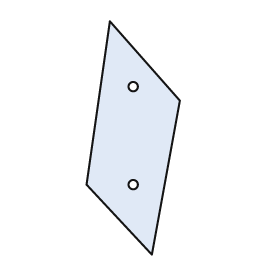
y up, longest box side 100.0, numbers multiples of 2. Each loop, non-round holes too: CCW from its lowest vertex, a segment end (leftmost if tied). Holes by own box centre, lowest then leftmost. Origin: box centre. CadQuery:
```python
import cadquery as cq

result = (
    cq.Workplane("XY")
    .moveTo(8.0, -50.0)
    .lineTo(20.0, 16.0)
    .lineTo(-10.0, 50.0)
    .lineTo(-20.0, -20.0)
    .close()
    .moveTo(0.0, -20.0)
    .circle(2.0)
    .moveTo(0.0, 22.0)
    .circle(2.0)
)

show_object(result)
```